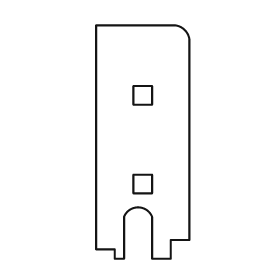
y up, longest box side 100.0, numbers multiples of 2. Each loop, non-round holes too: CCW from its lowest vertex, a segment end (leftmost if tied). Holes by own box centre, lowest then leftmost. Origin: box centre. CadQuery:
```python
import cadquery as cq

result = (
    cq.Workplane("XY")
    .moveTo(-12.0, -50.0)
    .lineTo(-8.0, -50.0)
    .lineTo(-8.0, -32.0)
    .threePointArc((-2.0, -28.0), (4.0, -32.0))
    .lineTo(4.0, -50.0)
    .lineTo(12.0, -50.0)
    .lineTo(12.0, -42.0)
    .lineTo(20.0, -42.0)
    .lineTo(20.0, 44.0)
    .threePointArc((18.0, 48.0), (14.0, 50.0))
    .lineTo(-20.0, 50.0)
    .lineTo(-20.0, -46.0)
    .lineTo(-12.0, -46.0)
    .close()
    .moveTo(-4.0, -22.0)
    .lineTo(4.0, -22.0)
    .lineTo(4.0, -14.0)
    .lineTo(-4.0, -14.0)
    .close()
    .moveTo(-4.0, 16.0)
    .lineTo(4.0, 16.0)
    .lineTo(4.0, 24.0)
    .lineTo(-4.0, 24.0)
    .close()
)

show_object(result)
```